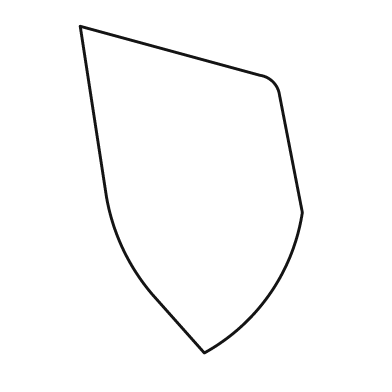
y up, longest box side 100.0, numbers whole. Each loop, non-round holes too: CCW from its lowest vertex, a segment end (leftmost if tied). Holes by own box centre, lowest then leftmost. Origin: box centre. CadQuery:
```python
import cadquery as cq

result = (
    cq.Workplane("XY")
    .moveTo(4.0, -50.0)
    .threePointArc((24.0, -32.0), (34.0, -7.0))
    .lineTo(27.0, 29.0)
    .threePointArc((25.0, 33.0), (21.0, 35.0))
    .lineTo(-34.0, 50.0)
    .lineTo(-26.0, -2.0)
    .threePointArc((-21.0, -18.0), (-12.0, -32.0))
    .close()
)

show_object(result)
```